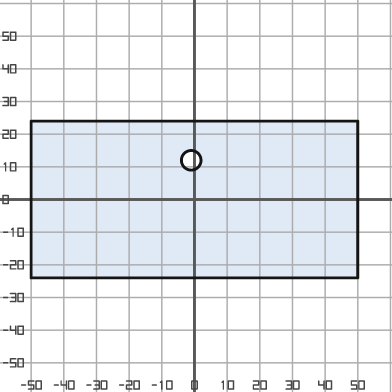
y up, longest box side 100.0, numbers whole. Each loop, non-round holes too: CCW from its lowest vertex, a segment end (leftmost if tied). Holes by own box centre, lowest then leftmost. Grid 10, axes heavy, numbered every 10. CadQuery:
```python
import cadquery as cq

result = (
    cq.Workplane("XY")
    .moveTo(-50.0, -24.0)
    .lineTo(50.0, -24.0)
    .lineTo(50.0, 24.0)
    .lineTo(-50.0, 24.0)
    .close()
    .moveTo(-1.0, 12.0)
    .circle(3.0)
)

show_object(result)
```